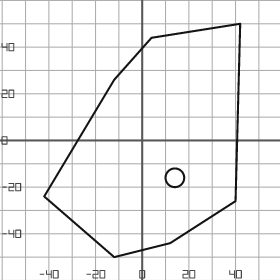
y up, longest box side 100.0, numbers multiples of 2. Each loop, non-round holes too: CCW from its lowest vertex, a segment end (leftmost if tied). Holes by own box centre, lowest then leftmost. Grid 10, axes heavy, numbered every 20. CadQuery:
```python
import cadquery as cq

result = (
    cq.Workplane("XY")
    .moveTo(-12.0, -50.0)
    .lineTo(12.0, -44.0)
    .lineTo(40.0, -26.0)
    .lineTo(42.0, 50.0)
    .lineTo(4.0, 44.0)
    .lineTo(-12.0, 26.0)
    .lineTo(-42.0, -24.0)
    .close()
    .moveTo(14.0, -16.0)
    .circle(4.0)
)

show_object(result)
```